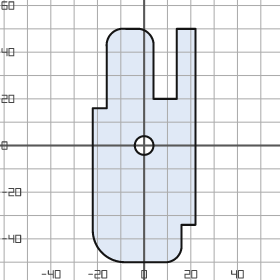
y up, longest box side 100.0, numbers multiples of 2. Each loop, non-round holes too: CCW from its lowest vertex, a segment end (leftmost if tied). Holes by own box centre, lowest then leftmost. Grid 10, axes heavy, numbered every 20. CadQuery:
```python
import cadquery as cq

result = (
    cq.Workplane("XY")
    .moveTo(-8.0, -50.0)
    .lineTo(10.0, -50.0)
    .threePointArc((14.0, -48.0), (16.0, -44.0))
    .lineTo(16.0, -34.0)
    .lineTo(22.0, -34.0)
    .lineTo(22.0, 50.0)
    .lineTo(14.0, 50.0)
    .lineTo(14.0, 20.0)
    .lineTo(4.0, 20.0)
    .lineTo(4.0, 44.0)
    .threePointArc((2.0, 48.0), (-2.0, 50.0))
    .lineTo(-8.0, 50.0)
    .threePointArc((-14.0, 48.0), (-16.0, 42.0))
    .lineTo(-16.0, 16.0)
    .lineTo(-22.0, 16.0)
    .lineTo(-22.0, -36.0)
    .threePointArc((-18.0, -46.0), (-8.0, -50.0))
    .close()
    .moveTo(0.0, 0.0)
    .circle(4.0)
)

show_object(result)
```